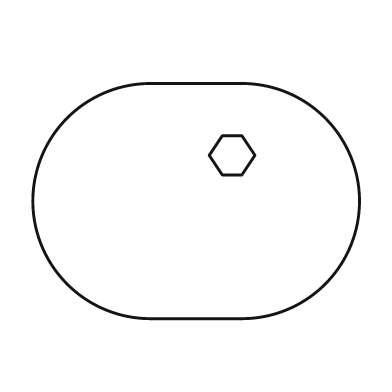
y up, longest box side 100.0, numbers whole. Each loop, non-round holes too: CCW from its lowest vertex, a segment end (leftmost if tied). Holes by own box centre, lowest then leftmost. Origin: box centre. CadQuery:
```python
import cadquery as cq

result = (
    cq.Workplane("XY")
    .moveTo(-14.0, -36.0)
    .lineTo(14.0, -36.0)
    .threePointArc((50.0, 0.0), (14.0, 36.0))
    .lineTo(-14.0, 36.0)
    .threePointArc((-50.0, 0.0), (-14.0, -36.0))
    .close()
    .moveTo(8.0, 8.0)
    .lineTo(14.0, 8.0)
    .lineTo(18.0, 14.0)
    .lineTo(14.0, 20.0)
    .lineTo(8.0, 20.0)
    .lineTo(4.0, 14.0)
    .close()
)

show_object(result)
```